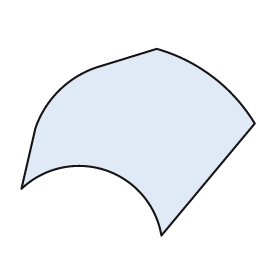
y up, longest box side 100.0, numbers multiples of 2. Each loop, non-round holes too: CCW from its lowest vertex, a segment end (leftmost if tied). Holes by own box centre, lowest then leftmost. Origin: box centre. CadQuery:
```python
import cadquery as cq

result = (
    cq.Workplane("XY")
    .moveTo(10.0, -40.0)
    .lineTo(50.0, 8.0)
    .threePointArc((32.0, 28.0), (8.0, 40.0))
    .lineTo(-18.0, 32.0)
    .threePointArc((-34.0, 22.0), (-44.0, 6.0))
    .lineTo(-50.0, -20.0)
    .threePointArc((-14.0, -12.0), (10.0, -40.0))
    .close()
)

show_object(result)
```